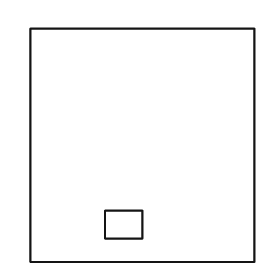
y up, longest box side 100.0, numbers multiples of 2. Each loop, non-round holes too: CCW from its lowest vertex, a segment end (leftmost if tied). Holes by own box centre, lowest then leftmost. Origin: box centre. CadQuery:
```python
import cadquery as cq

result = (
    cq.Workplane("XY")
    .moveTo(-48.0, -50.0)
    .lineTo(48.0, -50.0)
    .lineTo(48.0, 50.0)
    .lineTo(-48.0, 50.0)
    .close()
    .moveTo(-16.0, -40.0)
    .lineTo(0.0, -40.0)
    .lineTo(0.0, -28.0)
    .lineTo(-16.0, -28.0)
    .close()
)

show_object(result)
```